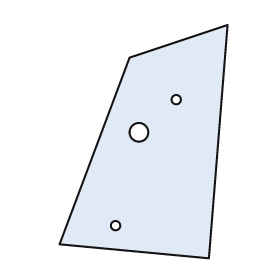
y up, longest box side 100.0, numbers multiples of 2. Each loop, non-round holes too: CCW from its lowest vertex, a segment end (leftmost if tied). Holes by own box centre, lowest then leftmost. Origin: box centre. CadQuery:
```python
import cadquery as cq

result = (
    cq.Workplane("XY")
    .moveTo(28.0, -50.0)
    .lineTo(36.0, 50.0)
    .lineTo(-6.0, 36.0)
    .lineTo(-36.0, -44.0)
    .close()
    .moveTo(-12.0, -36.0)
    .circle(2.0)
    .moveTo(-2.0, 4.0)
    .circle(4.0)
    .moveTo(14.0, 18.0)
    .circle(2.0)
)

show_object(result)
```